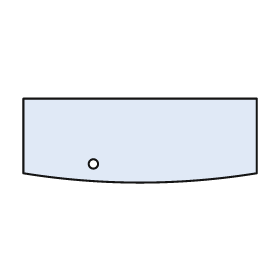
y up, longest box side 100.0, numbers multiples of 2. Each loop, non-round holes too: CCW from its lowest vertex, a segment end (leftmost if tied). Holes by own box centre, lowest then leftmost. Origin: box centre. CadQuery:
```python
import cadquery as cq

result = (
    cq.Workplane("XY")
    .moveTo(-50.0, -14.0)
    .threePointArc((0.0, -18.0), (50.0, -14.0))
    .lineTo(50.0, 18.0)
    .lineTo(-50.0, 18.0)
    .close()
    .moveTo(-20.0, -10.0)
    .circle(2.0)
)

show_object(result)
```